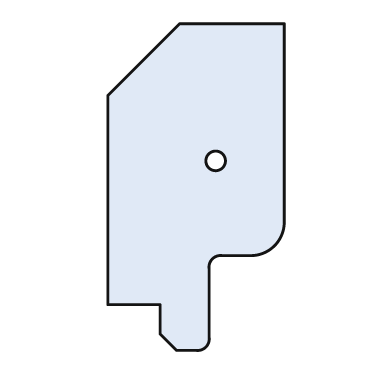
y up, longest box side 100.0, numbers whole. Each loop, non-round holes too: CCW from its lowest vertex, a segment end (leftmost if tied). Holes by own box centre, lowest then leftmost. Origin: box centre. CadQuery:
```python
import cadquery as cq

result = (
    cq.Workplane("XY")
    .moveTo(-6.0, -50.0)
    .lineTo(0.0, -50.0)
    .threePointArc((3.0, -49.0), (4.0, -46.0))
    .lineTo(4.0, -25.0)
    .threePointArc((5.0, -22.0), (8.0, -21.0))
    .lineTo(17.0, -21.0)
    .threePointArc((24.0, -18.0), (27.0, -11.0))
    .lineTo(27.0, 50.0)
    .lineTo(-5.0, 50.0)
    .lineTo(-27.0, 28.0)
    .lineTo(-27.0, -36.0)
    .lineTo(-11.0, -36.0)
    .lineTo(-11.0, -45.0)
    .close()
    .moveTo(6.0, 8.0)
    .circle(3.0)
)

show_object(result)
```